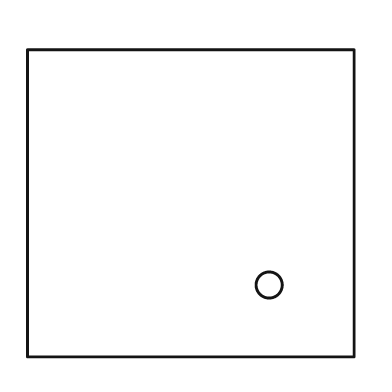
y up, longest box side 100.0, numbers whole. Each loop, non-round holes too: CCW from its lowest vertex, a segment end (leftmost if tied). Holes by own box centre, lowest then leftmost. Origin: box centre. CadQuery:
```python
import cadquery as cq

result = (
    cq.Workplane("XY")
    .moveTo(-50.0, -47.0)
    .lineTo(50.0, -47.0)
    .lineTo(50.0, 47.0)
    .lineTo(-50.0, 47.0)
    .close()
    .moveTo(24.0, -25.0)
    .circle(4.0)
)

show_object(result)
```